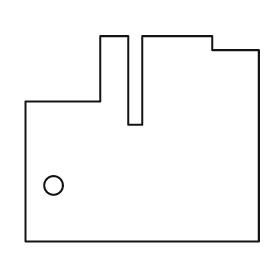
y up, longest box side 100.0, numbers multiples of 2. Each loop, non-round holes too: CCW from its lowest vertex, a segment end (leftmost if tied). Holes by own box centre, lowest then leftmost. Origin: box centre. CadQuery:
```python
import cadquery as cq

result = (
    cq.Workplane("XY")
    .moveTo(-50.0, -44.0)
    .lineTo(50.0, -44.0)
    .lineTo(50.0, 38.0)
    .lineTo(30.0, 38.0)
    .lineTo(30.0, 44.0)
    .lineTo(0.0, 44.0)
    .lineTo(0.0, 6.0)
    .lineTo(-6.0, 6.0)
    .lineTo(-6.0, 44.0)
    .lineTo(-18.0, 44.0)
    .lineTo(-18.0, 16.0)
    .lineTo(-50.0, 16.0)
    .close()
    .moveTo(-38.0, -20.0)
    .circle(4.0)
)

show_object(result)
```